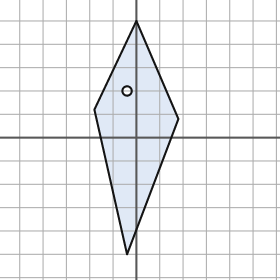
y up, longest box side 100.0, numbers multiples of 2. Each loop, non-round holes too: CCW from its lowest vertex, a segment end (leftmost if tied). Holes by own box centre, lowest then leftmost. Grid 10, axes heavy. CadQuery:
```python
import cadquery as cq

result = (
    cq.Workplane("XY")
    .moveTo(-4.0, -50.0)
    .lineTo(18.0, 8.0)
    .lineTo(0.0, 50.0)
    .lineTo(-18.0, 12.0)
    .close()
    .moveTo(-4.0, 20.0)
    .circle(2.0)
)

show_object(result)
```